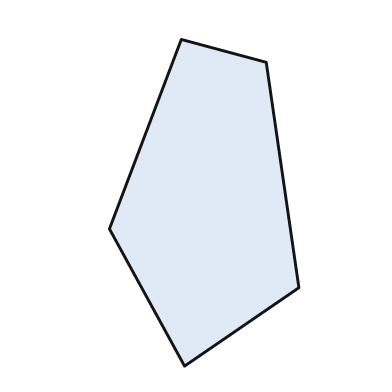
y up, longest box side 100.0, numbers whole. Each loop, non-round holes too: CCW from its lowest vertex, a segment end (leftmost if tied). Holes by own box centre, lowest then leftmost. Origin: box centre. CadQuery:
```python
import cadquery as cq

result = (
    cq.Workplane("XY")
    .moveTo(-6.0, -50.0)
    .lineTo(29.0, -26.0)
    .lineTo(19.0, 43.0)
    .lineTo(-7.0, 50.0)
    .lineTo(-29.0, -8.0)
    .close()
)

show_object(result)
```